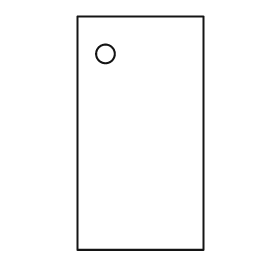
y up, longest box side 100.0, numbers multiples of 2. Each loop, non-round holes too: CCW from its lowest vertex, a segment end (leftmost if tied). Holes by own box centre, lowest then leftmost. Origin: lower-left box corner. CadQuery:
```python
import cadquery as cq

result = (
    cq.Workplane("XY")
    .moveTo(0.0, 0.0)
    .lineTo(54.0, 0.0)
    .lineTo(54.0, 100.0)
    .lineTo(0.0, 100.0)
    .close()
    .moveTo(12.0, 84.0)
    .circle(4.0)
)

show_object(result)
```